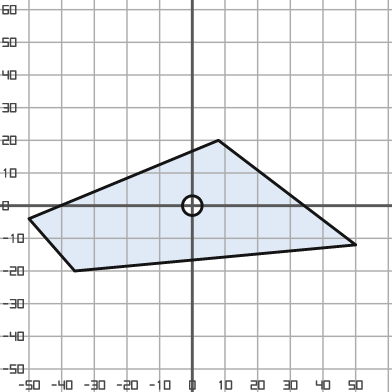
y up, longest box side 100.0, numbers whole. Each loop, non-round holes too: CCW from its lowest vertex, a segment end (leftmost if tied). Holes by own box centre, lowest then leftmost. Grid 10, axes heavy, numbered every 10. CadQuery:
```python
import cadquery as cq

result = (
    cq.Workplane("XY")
    .moveTo(-36.0, -20.0)
    .lineTo(50.0, -12.0)
    .lineTo(8.0, 20.0)
    .lineTo(-50.0, -4.0)
    .close()
    .moveTo(0.0, 0.0)
    .circle(3.0)
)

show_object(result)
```